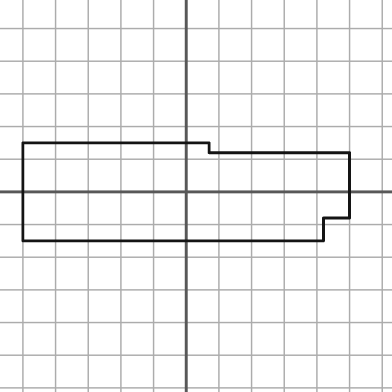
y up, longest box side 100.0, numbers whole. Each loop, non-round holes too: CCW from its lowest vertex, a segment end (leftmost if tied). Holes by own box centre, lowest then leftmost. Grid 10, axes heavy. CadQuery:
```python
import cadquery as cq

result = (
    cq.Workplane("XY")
    .moveTo(-50.0, -15.0)
    .lineTo(42.0, -15.0)
    .lineTo(42.0, -8.0)
    .lineTo(50.0, -8.0)
    .lineTo(50.0, 12.0)
    .lineTo(7.0, 12.0)
    .lineTo(7.0, 15.0)
    .lineTo(-50.0, 15.0)
    .close()
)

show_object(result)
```